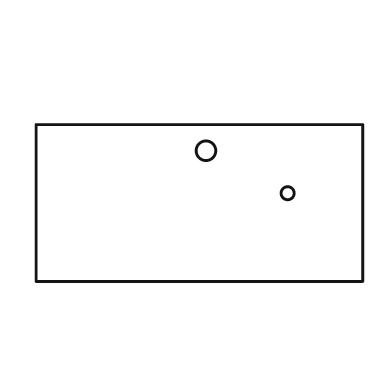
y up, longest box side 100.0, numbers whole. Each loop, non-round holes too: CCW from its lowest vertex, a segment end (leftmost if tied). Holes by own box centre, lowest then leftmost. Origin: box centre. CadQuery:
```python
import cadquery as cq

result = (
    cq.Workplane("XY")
    .moveTo(-50.0, -24.0)
    .lineTo(50.0, -24.0)
    .lineTo(50.0, 24.0)
    .lineTo(-50.0, 24.0)
    .close()
    .moveTo(27.0, 3.0)
    .circle(2.0)
    .moveTo(2.0, 16.0)
    .circle(3.0)
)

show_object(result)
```